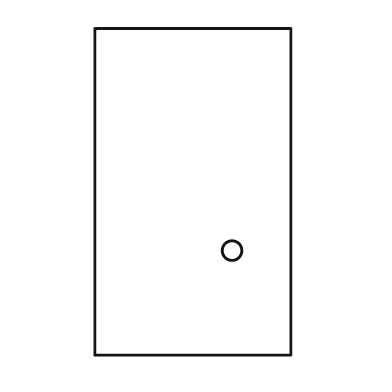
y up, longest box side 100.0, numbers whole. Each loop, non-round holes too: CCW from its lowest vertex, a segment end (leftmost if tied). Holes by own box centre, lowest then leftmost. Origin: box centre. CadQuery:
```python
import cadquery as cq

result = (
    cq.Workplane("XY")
    .moveTo(-30.0, -50.0)
    .lineTo(30.0, -50.0)
    .lineTo(30.0, 50.0)
    .lineTo(-30.0, 50.0)
    .close()
    .moveTo(12.0, -18.0)
    .circle(3.0)
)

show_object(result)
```